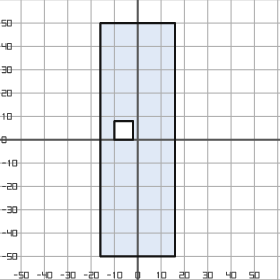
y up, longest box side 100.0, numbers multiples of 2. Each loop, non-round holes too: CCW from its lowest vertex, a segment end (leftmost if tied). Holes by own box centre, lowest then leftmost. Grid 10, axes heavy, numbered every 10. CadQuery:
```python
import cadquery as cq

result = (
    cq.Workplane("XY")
    .moveTo(-16.0, -50.0)
    .lineTo(16.0, -50.0)
    .lineTo(16.0, 50.0)
    .lineTo(-16.0, 50.0)
    .close()
    .moveTo(-10.0, 0.0)
    .lineTo(-2.0, 0.0)
    .lineTo(-2.0, 8.0)
    .lineTo(-10.0, 8.0)
    .close()
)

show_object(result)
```